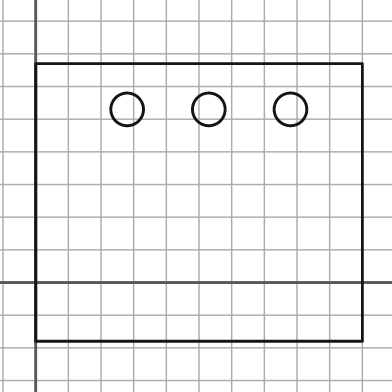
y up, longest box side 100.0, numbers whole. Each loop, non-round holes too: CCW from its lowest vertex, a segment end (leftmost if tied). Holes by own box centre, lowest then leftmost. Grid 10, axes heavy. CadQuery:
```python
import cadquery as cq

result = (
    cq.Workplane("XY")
    .moveTo(0.0, -18.0)
    .lineTo(100.0, -18.0)
    .lineTo(100.0, 67.0)
    .lineTo(0.0, 67.0)
    .close()
    .moveTo(28.0, 53.0)
    .circle(5.0)
    .moveTo(53.0, 53.0)
    .circle(5.0)
    .moveTo(78.0, 53.0)
    .circle(5.0)
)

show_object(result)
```